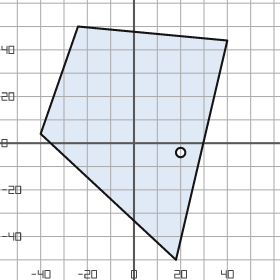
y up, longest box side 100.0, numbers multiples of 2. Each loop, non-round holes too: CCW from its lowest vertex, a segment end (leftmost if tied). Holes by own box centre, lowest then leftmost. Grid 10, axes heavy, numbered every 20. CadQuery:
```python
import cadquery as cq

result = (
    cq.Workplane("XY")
    .moveTo(18.0, -50.0)
    .lineTo(40.0, 44.0)
    .lineTo(-24.0, 50.0)
    .lineTo(-40.0, 4.0)
    .close()
    .moveTo(20.0, -4.0)
    .circle(2.0)
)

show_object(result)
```